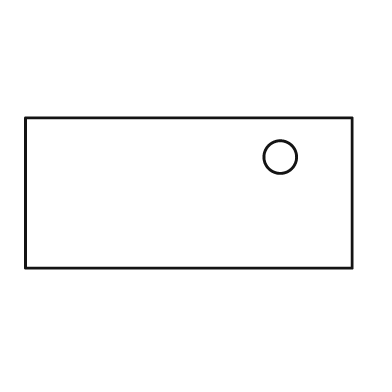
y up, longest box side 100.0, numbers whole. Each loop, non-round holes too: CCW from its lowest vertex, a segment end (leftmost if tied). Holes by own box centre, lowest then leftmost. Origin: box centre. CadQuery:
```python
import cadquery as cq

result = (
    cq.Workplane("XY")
    .moveTo(-50.0, -23.0)
    .lineTo(50.0, -23.0)
    .lineTo(50.0, 23.0)
    .lineTo(-50.0, 23.0)
    .close()
    .moveTo(28.0, 11.0)
    .circle(5.0)
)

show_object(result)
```